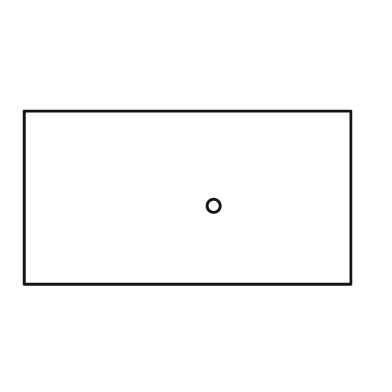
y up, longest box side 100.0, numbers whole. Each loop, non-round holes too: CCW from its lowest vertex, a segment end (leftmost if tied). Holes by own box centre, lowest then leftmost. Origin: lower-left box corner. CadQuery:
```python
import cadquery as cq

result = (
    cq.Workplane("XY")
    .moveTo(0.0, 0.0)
    .lineTo(100.0, 0.0)
    .lineTo(100.0, 53.0)
    .lineTo(0.0, 53.0)
    .close()
    .moveTo(58.0, 24.0)
    .circle(2.0)
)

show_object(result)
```